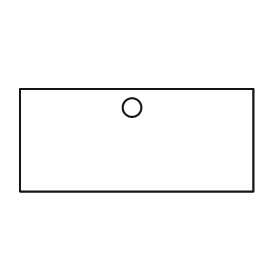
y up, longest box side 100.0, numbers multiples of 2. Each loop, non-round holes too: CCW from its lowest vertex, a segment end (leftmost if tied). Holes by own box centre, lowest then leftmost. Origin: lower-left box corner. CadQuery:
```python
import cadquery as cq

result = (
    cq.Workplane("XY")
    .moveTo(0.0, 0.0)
    .lineTo(100.0, 0.0)
    .lineTo(100.0, 44.0)
    .lineTo(0.0, 44.0)
    .close()
    .moveTo(48.0, 36.0)
    .circle(4.0)
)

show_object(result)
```